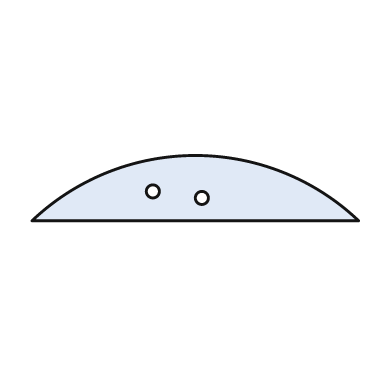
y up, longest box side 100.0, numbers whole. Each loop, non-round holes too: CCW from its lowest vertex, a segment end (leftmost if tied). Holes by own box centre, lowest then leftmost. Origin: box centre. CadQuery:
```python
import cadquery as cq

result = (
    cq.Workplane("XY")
    .moveTo(-50.0, -10.0)
    .lineTo(50.0, -10.0)
    .threePointArc((0.0, 10.0), (-50.0, -10.0))
    .close()
    .moveTo(2.0, -3.0)
    .circle(2.0)
    .moveTo(-13.0, -1.0)
    .circle(2.0)
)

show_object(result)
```